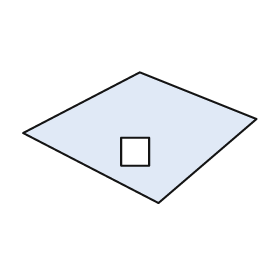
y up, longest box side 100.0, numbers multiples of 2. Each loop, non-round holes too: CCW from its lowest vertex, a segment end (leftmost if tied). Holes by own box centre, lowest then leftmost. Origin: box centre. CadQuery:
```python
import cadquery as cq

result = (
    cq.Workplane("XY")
    .moveTo(8.0, -28.0)
    .lineTo(50.0, 8.0)
    .lineTo(0.0, 28.0)
    .lineTo(-50.0, 2.0)
    .close()
    .moveTo(-8.0, -12.0)
    .lineTo(4.0, -12.0)
    .lineTo(4.0, 0.0)
    .lineTo(-8.0, 0.0)
    .close()
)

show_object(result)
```